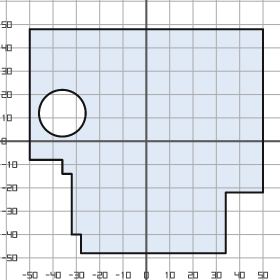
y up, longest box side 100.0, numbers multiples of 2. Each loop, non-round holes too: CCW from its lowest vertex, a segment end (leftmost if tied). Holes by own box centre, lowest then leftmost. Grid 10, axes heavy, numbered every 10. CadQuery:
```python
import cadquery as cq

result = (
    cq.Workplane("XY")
    .moveTo(-28.0, -48.0)
    .lineTo(34.0, -48.0)
    .lineTo(34.0, -22.0)
    .lineTo(50.0, -22.0)
    .lineTo(50.0, 48.0)
    .lineTo(-50.0, 48.0)
    .lineTo(-50.0, -8.0)
    .lineTo(-36.0, -8.0)
    .lineTo(-36.0, -14.0)
    .lineTo(-32.0, -14.0)
    .lineTo(-32.0, -40.0)
    .lineTo(-28.0, -40.0)
    .close()
    .moveTo(-36.0, 12.0)
    .circle(10.0)
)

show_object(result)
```